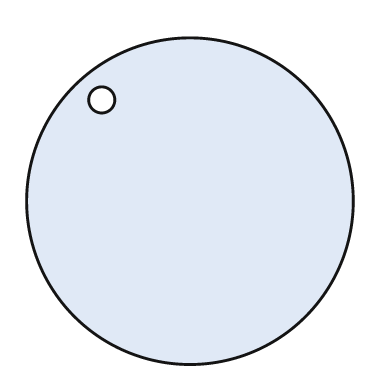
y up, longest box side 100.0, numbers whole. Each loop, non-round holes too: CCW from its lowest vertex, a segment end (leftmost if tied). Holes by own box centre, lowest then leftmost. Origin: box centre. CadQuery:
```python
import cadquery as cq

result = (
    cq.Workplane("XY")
    .moveTo(0.0, 0.0)
    .circle(50.0)
    .moveTo(-27.0, 31.0)
    .circle(4.0)
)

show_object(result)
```